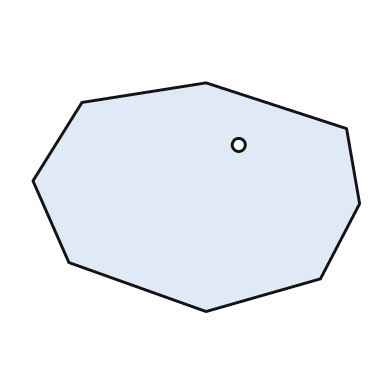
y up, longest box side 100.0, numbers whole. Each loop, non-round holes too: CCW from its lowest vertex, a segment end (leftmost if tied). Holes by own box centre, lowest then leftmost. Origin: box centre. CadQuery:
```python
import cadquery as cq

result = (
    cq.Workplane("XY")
    .moveTo(3.0, -35.0)
    .lineTo(38.0, -25.0)
    .lineTo(50.0, -2.0)
    .lineTo(46.0, 21.0)
    .lineTo(3.0, 35.0)
    .lineTo(-35.0, 29.0)
    .lineTo(-50.0, 5.0)
    .lineTo(-39.0, -20.0)
    .close()
    .moveTo(13.0, 16.0)
    .circle(2.0)
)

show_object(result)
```